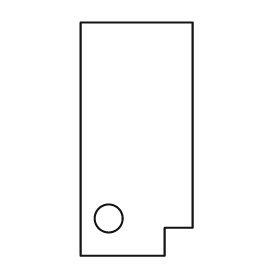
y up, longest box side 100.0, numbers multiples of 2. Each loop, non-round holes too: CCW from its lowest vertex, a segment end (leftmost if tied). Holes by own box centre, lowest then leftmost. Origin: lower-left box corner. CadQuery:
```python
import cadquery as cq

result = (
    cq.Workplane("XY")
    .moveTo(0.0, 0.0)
    .lineTo(36.0, 0.0)
    .lineTo(36.0, 12.0)
    .lineTo(48.0, 12.0)
    .lineTo(48.0, 100.0)
    .lineTo(0.0, 100.0)
    .close()
    .moveTo(12.0, 16.0)
    .circle(6.0)
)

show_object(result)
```